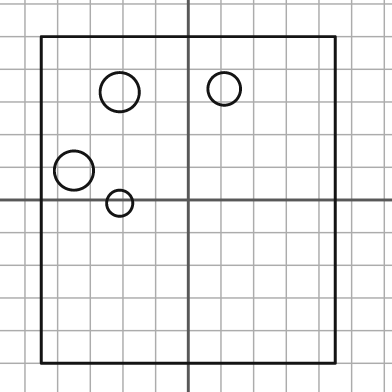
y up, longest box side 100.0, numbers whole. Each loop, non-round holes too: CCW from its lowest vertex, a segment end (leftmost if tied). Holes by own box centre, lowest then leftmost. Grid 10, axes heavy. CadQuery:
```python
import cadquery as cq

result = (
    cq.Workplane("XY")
    .moveTo(-45.0, -50.0)
    .lineTo(45.0, -50.0)
    .lineTo(45.0, 50.0)
    .lineTo(-45.0, 50.0)
    .close()
    .moveTo(-21.0, -1.0)
    .circle(4.0)
    .moveTo(-35.0, 9.0)
    .circle(6.0)
    .moveTo(-21.0, 33.0)
    .circle(6.0)
    .moveTo(11.0, 34.0)
    .circle(5.0)
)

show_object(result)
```